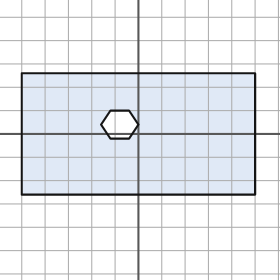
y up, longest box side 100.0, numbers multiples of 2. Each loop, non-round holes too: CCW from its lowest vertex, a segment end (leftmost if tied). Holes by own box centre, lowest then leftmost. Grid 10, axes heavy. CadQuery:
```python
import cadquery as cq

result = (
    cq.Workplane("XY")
    .moveTo(-50.0, -26.0)
    .lineTo(50.0, -26.0)
    .lineTo(50.0, 26.0)
    .lineTo(-50.0, 26.0)
    .close()
    .moveTo(-12.0, -2.0)
    .lineTo(-4.0, -2.0)
    .lineTo(0.0, 4.0)
    .lineTo(-4.0, 10.0)
    .lineTo(-12.0, 10.0)
    .lineTo(-16.0, 4.0)
    .close()
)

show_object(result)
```